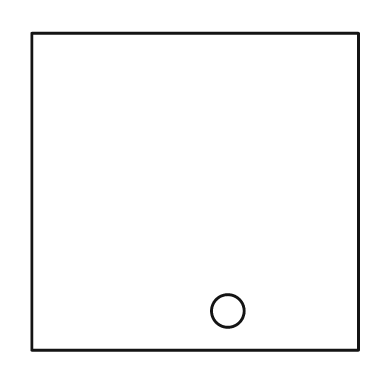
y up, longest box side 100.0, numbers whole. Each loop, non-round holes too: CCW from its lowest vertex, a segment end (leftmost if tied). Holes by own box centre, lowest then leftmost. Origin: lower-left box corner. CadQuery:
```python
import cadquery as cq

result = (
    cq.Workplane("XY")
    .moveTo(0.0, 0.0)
    .lineTo(100.0, 0.0)
    .lineTo(100.0, 97.0)
    .lineTo(0.0, 97.0)
    .close()
    .moveTo(60.0, 12.0)
    .circle(5.0)
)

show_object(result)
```